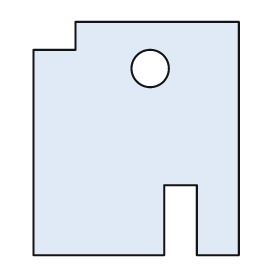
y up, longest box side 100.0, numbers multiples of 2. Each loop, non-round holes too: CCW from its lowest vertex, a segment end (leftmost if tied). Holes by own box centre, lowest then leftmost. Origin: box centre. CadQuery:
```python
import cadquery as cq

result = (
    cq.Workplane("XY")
    .moveTo(-44.0, -50.0)
    .lineTo(12.0, -50.0)
    .lineTo(12.0, -20.0)
    .lineTo(26.0, -20.0)
    .lineTo(26.0, -50.0)
    .lineTo(44.0, -50.0)
    .lineTo(44.0, 50.0)
    .lineTo(-26.0, 50.0)
    .lineTo(-26.0, 38.0)
    .lineTo(-44.0, 38.0)
    .close()
    .moveTo(6.0, 30.0)
    .circle(8.0)
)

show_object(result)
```